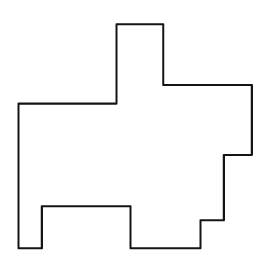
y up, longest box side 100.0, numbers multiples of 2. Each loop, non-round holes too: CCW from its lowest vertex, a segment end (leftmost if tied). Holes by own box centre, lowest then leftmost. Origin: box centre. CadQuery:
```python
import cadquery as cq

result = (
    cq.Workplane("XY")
    .moveTo(-50.0, -48.0)
    .lineTo(-40.0, -48.0)
    .lineTo(-40.0, -30.0)
    .lineTo(-2.0, -30.0)
    .lineTo(-2.0, -48.0)
    .lineTo(28.0, -48.0)
    .lineTo(28.0, -36.0)
    .lineTo(38.0, -36.0)
    .lineTo(38.0, -8.0)
    .lineTo(50.0, -8.0)
    .lineTo(50.0, 22.0)
    .lineTo(12.0, 22.0)
    .lineTo(12.0, 48.0)
    .lineTo(-8.0, 48.0)
    .lineTo(-8.0, 14.0)
    .lineTo(-50.0, 14.0)
    .close()
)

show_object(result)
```